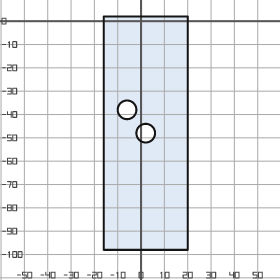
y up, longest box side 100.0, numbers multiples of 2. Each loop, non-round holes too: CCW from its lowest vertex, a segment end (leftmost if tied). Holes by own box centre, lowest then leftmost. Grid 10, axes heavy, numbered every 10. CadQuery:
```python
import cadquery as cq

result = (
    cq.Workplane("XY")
    .moveTo(-16.0, -98.0)
    .lineTo(20.0, -98.0)
    .lineTo(20.0, 2.0)
    .lineTo(-16.0, 2.0)
    .close()
    .moveTo(2.0, -48.0)
    .circle(4.0)
    .moveTo(-6.0, -38.0)
    .circle(4.0)
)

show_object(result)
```